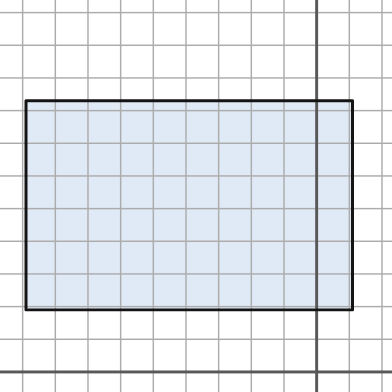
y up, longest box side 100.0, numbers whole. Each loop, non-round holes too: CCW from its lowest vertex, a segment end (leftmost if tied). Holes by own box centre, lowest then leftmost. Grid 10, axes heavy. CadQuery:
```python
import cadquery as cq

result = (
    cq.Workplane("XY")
    .moveTo(-89.0, 19.0)
    .lineTo(11.0, 19.0)
    .lineTo(11.0, 83.0)
    .lineTo(-89.0, 83.0)
    .close()
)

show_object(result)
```